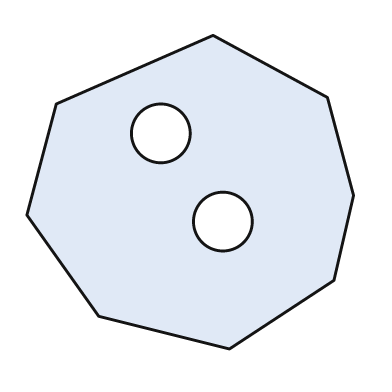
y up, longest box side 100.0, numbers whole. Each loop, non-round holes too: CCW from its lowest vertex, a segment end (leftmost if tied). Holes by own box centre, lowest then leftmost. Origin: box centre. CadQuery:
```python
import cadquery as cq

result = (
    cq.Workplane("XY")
    .moveTo(12.0, -48.0)
    .lineTo(44.0, -27.0)
    .lineTo(50.0, -1.0)
    .lineTo(42.0, 29.0)
    .lineTo(7.0, 48.0)
    .lineTo(-41.0, 27.0)
    .lineTo(-50.0, -7.0)
    .lineTo(-28.0, -38.0)
    .close()
    .moveTo(10.0, -9.0)
    .circle(9.0)
    .moveTo(-9.0, 18.0)
    .circle(9.0)
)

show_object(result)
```